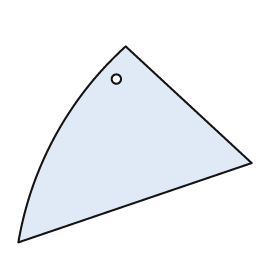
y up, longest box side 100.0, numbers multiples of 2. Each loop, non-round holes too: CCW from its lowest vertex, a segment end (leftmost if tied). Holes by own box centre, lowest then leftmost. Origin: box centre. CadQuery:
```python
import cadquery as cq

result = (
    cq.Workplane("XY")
    .moveTo(-50.0, -42.0)
    .lineTo(50.0, -8.0)
    .lineTo(-4.0, 42.0)
    .threePointArc((-34.0, 4.0), (-50.0, -42.0))
    .close()
    .moveTo(-8.0, 28.0)
    .circle(2.0)
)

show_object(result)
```